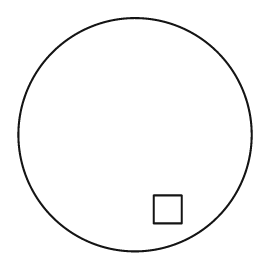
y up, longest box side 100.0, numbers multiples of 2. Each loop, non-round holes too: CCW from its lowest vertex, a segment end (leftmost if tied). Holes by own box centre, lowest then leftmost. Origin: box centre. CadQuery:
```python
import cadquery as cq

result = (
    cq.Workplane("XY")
    .moveTo(0.0, 0.0)
    .circle(50.0)
    .moveTo(8.0, -38.0)
    .lineTo(20.0, -38.0)
    .lineTo(20.0, -26.0)
    .lineTo(8.0, -26.0)
    .close()
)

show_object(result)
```